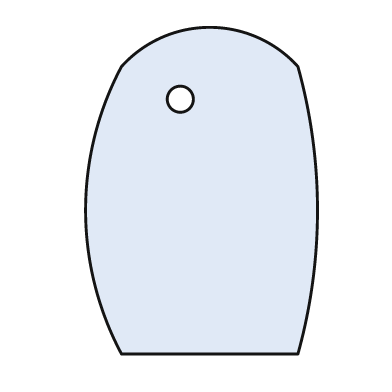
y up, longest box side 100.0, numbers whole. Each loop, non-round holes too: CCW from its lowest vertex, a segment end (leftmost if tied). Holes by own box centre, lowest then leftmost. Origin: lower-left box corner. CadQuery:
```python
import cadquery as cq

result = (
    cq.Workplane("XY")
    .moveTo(11.0, 0.0)
    .lineTo(65.0, 0.0)
    .threePointArc((71.0, 44.0), (65.0, 88.0))
    .threePointArc((38.0, 100.0), (11.0, 88.0))
    .threePointArc((0.0, 44.0), (11.0, 0.0))
    .close()
    .moveTo(29.0, 78.0)
    .circle(4.0)
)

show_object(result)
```